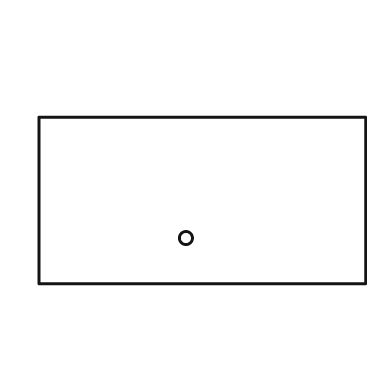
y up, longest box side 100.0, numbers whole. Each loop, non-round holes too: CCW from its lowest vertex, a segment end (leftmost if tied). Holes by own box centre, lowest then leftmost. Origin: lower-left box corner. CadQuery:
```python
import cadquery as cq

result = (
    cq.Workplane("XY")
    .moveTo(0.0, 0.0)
    .lineTo(100.0, 0.0)
    .lineTo(100.0, 51.0)
    .lineTo(0.0, 51.0)
    .close()
    .moveTo(45.0, 14.0)
    .circle(2.0)
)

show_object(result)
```